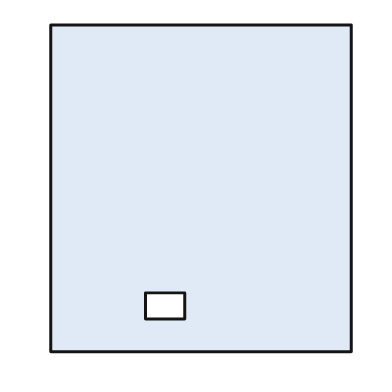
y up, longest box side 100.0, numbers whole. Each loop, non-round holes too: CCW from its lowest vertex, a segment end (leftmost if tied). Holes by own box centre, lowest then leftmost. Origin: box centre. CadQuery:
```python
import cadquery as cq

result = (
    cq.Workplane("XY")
    .moveTo(-46.0, -50.0)
    .lineTo(46.0, -50.0)
    .lineTo(46.0, 50.0)
    .lineTo(-46.0, 50.0)
    .close()
    .moveTo(-17.0, -40.0)
    .lineTo(-5.0, -40.0)
    .lineTo(-5.0, -32.0)
    .lineTo(-17.0, -32.0)
    .close()
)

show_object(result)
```